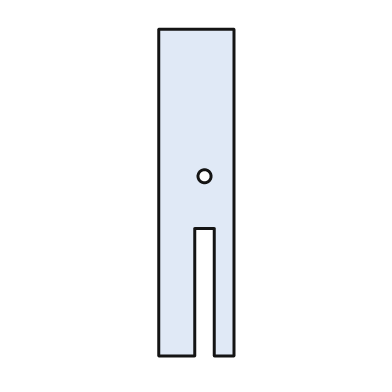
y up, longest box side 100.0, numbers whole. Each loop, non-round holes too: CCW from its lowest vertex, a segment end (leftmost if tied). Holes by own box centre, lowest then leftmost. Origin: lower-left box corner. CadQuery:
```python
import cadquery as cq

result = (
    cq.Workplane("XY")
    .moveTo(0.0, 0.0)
    .lineTo(11.0, 0.0)
    .lineTo(11.0, 39.0)
    .lineTo(17.0, 39.0)
    .lineTo(17.0, 0.0)
    .lineTo(23.0, 0.0)
    .lineTo(23.0, 100.0)
    .lineTo(0.0, 100.0)
    .close()
    .moveTo(14.0, 55.0)
    .circle(2.0)
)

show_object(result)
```